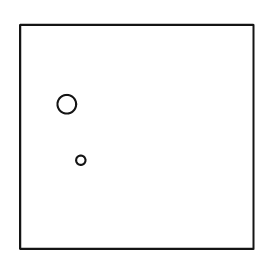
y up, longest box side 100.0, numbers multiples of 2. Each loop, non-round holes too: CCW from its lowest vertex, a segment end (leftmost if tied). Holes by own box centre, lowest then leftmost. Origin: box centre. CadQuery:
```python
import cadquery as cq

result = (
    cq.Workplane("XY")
    .moveTo(-50.0, -48.0)
    .lineTo(50.0, -48.0)
    .lineTo(50.0, 48.0)
    .lineTo(-50.0, 48.0)
    .close()
    .moveTo(-24.0, -10.0)
    .circle(2.0)
    .moveTo(-30.0, 14.0)
    .circle(4.0)
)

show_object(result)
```